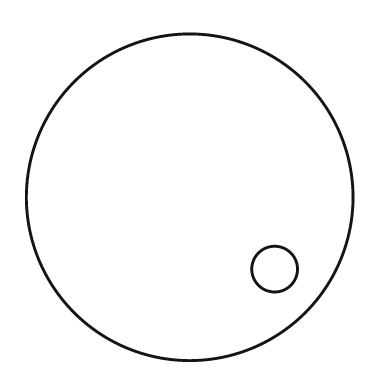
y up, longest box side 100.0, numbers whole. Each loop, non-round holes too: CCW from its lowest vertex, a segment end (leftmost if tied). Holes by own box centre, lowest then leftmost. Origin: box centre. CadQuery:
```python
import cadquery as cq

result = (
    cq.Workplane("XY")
    .moveTo(0.0, 0.0)
    .circle(50.0)
    .moveTo(26.0, -22.0)
    .circle(7.0)
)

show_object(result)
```